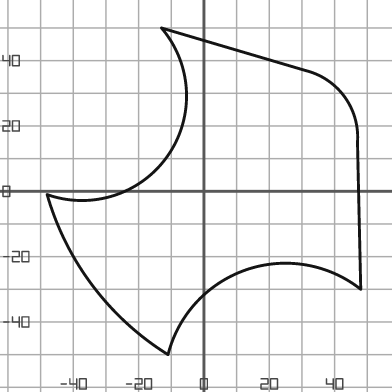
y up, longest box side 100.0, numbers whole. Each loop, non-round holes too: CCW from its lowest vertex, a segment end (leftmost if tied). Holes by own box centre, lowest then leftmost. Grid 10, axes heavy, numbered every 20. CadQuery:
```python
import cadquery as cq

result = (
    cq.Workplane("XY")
    .moveTo(-11.0, -50.0)
    .threePointArc((13.0, -24.0), (48.0, -30.0))
    .lineTo(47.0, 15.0)
    .threePointArc((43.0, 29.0), (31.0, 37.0))
    .lineTo(-13.0, 50.0)
    .threePointArc((-11.0, 11.0), (-48.0, -1.0))
    .threePointArc((-34.0, -29.0), (-11.0, -50.0))
    .close()
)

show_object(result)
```